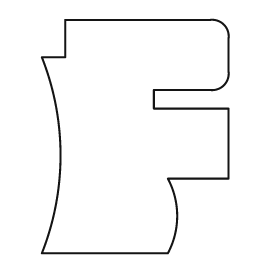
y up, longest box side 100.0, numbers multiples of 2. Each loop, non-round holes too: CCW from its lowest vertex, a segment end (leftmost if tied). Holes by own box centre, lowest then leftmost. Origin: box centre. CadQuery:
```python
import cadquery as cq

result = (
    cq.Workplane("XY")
    .moveTo(-40.0, -50.0)
    .lineTo(14.0, -50.0)
    .threePointArc((18.0, -34.0), (14.0, -18.0))
    .lineTo(40.0, -18.0)
    .lineTo(40.0, 12.0)
    .lineTo(8.0, 12.0)
    .lineTo(8.0, 20.0)
    .lineTo(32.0, 20.0)
    .threePointArc((38.0, 22.0), (40.0, 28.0))
    .lineTo(40.0, 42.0)
    .threePointArc((38.0, 48.0), (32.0, 50.0))
    .lineTo(-30.0, 50.0)
    .lineTo(-30.0, 34.0)
    .lineTo(-40.0, 34.0)
    .threePointArc((-32.0, -8.0), (-40.0, -50.0))
    .close()
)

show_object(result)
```